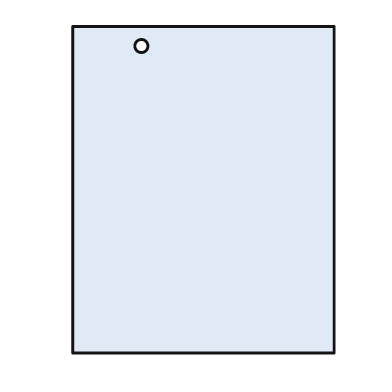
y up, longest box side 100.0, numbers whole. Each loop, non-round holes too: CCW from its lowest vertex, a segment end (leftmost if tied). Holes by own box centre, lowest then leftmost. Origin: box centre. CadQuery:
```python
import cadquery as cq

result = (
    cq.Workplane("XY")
    .moveTo(-40.0, -50.0)
    .lineTo(40.0, -50.0)
    .lineTo(40.0, 50.0)
    .lineTo(-40.0, 50.0)
    .close()
    .moveTo(-19.0, 44.0)
    .circle(2.0)
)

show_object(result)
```